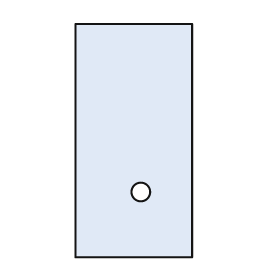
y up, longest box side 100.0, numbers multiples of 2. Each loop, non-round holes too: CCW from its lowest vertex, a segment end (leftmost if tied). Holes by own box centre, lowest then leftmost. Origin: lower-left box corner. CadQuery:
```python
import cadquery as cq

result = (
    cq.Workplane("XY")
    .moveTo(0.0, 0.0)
    .lineTo(50.0, 0.0)
    .lineTo(50.0, 100.0)
    .lineTo(0.0, 100.0)
    .close()
    .moveTo(28.0, 28.0)
    .circle(4.0)
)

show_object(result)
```